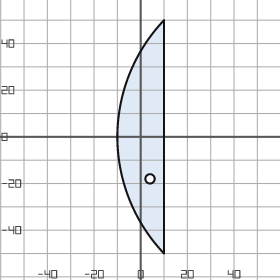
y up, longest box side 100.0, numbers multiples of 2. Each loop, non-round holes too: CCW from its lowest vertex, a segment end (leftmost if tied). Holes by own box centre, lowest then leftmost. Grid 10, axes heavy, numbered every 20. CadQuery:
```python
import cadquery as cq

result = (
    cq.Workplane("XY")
    .moveTo(10.0, -50.0)
    .lineTo(10.0, 50.0)
    .threePointArc((-10.0, 0.0), (10.0, -50.0))
    .close()
    .moveTo(4.0, -18.0)
    .circle(2.0)
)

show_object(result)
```